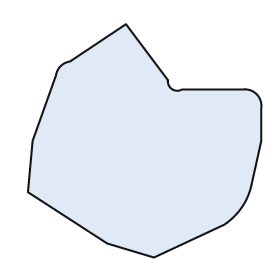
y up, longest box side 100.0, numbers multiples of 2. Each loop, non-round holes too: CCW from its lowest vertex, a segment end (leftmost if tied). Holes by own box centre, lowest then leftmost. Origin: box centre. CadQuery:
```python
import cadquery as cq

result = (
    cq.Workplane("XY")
    .moveTo(4.0, -50.0)
    .lineTo(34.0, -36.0)
    .threePointArc((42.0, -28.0), (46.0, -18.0))
    .lineTo(50.0, 0.0)
    .lineTo(50.0, 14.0)
    .threePointArc((48.0, 20.0), (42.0, 22.0))
    .lineTo(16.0, 22.0)
    .threePointArc((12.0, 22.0), (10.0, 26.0))
    .lineTo(-8.0, 50.0)
    .lineTo(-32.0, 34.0)
    .threePointArc((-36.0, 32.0), (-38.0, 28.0))
    .lineTo(-48.0, 0.0)
    .lineTo(-50.0, -22.0)
    .lineTo(-16.0, -44.0)
    .close()
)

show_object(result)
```